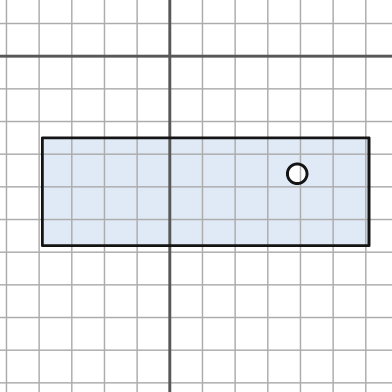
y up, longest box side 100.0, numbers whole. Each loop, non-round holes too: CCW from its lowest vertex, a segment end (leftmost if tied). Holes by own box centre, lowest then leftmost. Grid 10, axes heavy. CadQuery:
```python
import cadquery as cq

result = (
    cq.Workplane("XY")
    .moveTo(-39.0, -58.0)
    .lineTo(61.0, -58.0)
    .lineTo(61.0, -25.0)
    .lineTo(-39.0, -25.0)
    .close()
    .moveTo(39.0, -36.0)
    .circle(3.0)
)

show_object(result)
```